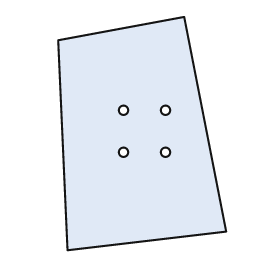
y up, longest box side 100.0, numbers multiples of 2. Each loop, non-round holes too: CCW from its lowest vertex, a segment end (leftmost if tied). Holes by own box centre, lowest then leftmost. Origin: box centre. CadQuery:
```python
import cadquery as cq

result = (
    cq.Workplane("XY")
    .moveTo(-32.0, -50.0)
    .lineTo(36.0, -42.0)
    .lineTo(18.0, 50.0)
    .lineTo(-36.0, 40.0)
    .close()
    .moveTo(-8.0, -8.0)
    .circle(2.0)
    .moveTo(10.0, -8.0)
    .circle(2.0)
    .moveTo(-8.0, 10.0)
    .circle(2.0)
    .moveTo(10.0, 10.0)
    .circle(2.0)
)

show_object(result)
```